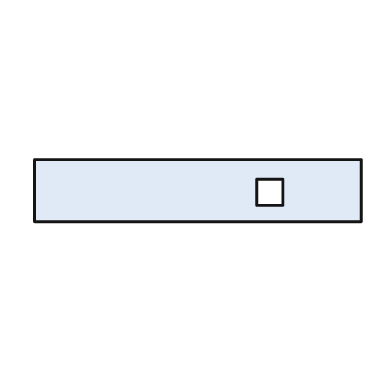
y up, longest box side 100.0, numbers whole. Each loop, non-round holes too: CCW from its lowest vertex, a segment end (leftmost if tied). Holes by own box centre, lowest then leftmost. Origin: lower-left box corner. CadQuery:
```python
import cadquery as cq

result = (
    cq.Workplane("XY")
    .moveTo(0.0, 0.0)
    .lineTo(100.0, 0.0)
    .lineTo(100.0, 19.0)
    .lineTo(0.0, 19.0)
    .close()
    .moveTo(68.0, 5.0)
    .lineTo(76.0, 5.0)
    .lineTo(76.0, 13.0)
    .lineTo(68.0, 13.0)
    .close()
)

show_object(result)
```